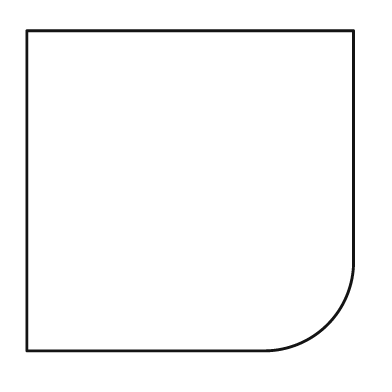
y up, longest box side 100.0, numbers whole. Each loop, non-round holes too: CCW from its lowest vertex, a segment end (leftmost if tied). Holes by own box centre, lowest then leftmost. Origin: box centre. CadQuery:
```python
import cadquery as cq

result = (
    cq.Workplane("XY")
    .moveTo(-50.0, -49.0)
    .lineTo(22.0, -49.0)
    .threePointArc((42.0, -41.0), (50.0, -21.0))
    .lineTo(50.0, 49.0)
    .lineTo(-50.0, 49.0)
    .close()
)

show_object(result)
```